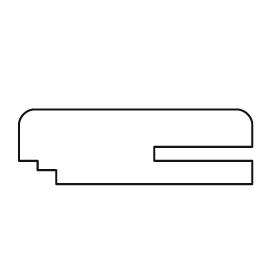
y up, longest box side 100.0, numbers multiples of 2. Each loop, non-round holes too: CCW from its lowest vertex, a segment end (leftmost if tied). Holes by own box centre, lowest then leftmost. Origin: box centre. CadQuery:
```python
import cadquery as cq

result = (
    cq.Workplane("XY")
    .moveTo(-34.0, -16.0)
    .lineTo(50.0, -16.0)
    .lineTo(50.0, -6.0)
    .lineTo(8.0, -6.0)
    .lineTo(8.0, 0.0)
    .lineTo(50.0, 0.0)
    .lineTo(50.0, 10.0)
    .threePointArc((48.0, 14.0), (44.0, 16.0))
    .lineTo(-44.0, 16.0)
    .threePointArc((-48.0, 14.0), (-50.0, 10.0))
    .lineTo(-50.0, -6.0)
    .lineTo(-42.0, -6.0)
    .lineTo(-42.0, -10.0)
    .lineTo(-34.0, -10.0)
    .close()
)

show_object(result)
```